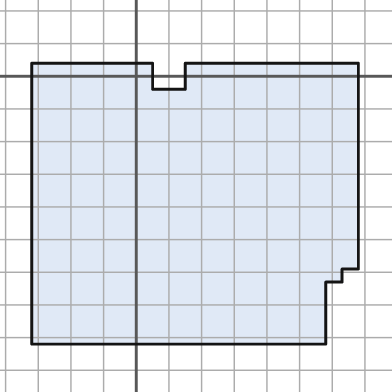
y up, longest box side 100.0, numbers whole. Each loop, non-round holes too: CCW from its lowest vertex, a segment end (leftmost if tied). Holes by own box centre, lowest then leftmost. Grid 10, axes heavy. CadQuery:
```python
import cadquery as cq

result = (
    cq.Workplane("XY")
    .moveTo(-32.0, -82.0)
    .lineTo(58.0, -82.0)
    .lineTo(58.0, -63.0)
    .lineTo(63.0, -63.0)
    .lineTo(63.0, -59.0)
    .lineTo(68.0, -59.0)
    .lineTo(68.0, 4.0)
    .lineTo(15.0, 4.0)
    .lineTo(15.0, -4.0)
    .lineTo(5.0, -4.0)
    .lineTo(5.0, 4.0)
    .lineTo(-32.0, 4.0)
    .close()
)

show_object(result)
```